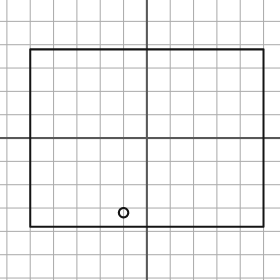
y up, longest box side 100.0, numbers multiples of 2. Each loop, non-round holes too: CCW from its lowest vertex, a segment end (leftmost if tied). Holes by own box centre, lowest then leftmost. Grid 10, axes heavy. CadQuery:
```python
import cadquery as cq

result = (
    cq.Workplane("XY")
    .moveTo(-50.0, -38.0)
    .lineTo(50.0, -38.0)
    .lineTo(50.0, 38.0)
    .lineTo(-50.0, 38.0)
    .close()
    .moveTo(-10.0, -32.0)
    .circle(2.0)
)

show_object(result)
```